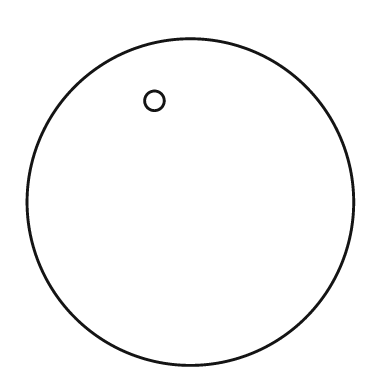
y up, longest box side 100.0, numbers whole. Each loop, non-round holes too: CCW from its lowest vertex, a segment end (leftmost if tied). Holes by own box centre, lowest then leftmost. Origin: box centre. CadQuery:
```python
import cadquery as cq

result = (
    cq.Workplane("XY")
    .moveTo(0.0, 0.0)
    .circle(50.0)
    .moveTo(-11.0, 31.0)
    .circle(3.0)
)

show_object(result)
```